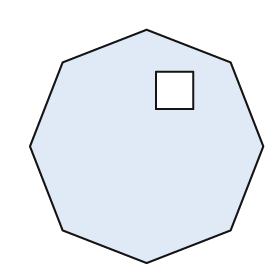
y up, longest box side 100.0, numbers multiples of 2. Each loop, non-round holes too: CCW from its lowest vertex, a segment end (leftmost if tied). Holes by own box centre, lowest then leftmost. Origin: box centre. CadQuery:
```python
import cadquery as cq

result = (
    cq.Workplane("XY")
    .moveTo(0.0, -50.0)
    .lineTo(36.0, -36.0)
    .lineTo(50.0, 0.0)
    .lineTo(36.0, 36.0)
    .lineTo(0.0, 50.0)
    .lineTo(-36.0, 36.0)
    .lineTo(-50.0, 0.0)
    .lineTo(-36.0, -36.0)
    .close()
    .moveTo(4.0, 16.0)
    .lineTo(20.0, 16.0)
    .lineTo(20.0, 32.0)
    .lineTo(4.0, 32.0)
    .close()
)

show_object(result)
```